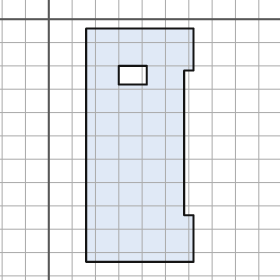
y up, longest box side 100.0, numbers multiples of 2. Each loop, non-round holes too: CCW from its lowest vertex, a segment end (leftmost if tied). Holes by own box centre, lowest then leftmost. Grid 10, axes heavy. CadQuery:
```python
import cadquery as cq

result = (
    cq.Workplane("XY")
    .moveTo(16.0, -104.0)
    .lineTo(62.0, -104.0)
    .lineTo(62.0, -84.0)
    .lineTo(58.0, -84.0)
    .lineTo(58.0, -22.0)
    .lineTo(62.0, -22.0)
    .lineTo(62.0, -4.0)
    .lineTo(16.0, -4.0)
    .close()
    .moveTo(30.0, -28.0)
    .lineTo(42.0, -28.0)
    .lineTo(42.0, -20.0)
    .lineTo(30.0, -20.0)
    .close()
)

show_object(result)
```